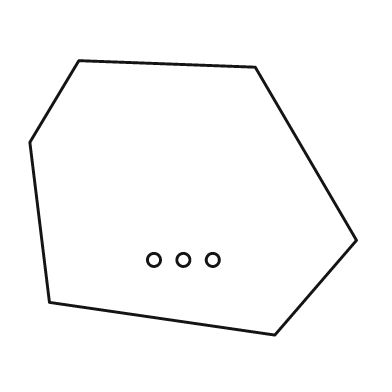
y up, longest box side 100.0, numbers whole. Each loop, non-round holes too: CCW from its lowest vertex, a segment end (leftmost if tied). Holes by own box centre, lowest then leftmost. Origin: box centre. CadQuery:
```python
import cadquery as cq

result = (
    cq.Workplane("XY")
    .moveTo(25.0, -42.0)
    .lineTo(50.0, -13.0)
    .lineTo(19.0, 40.0)
    .lineTo(-35.0, 42.0)
    .lineTo(-50.0, 17.0)
    .lineTo(-44.0, -32.0)
    .close()
    .moveTo(-12.0, -19.0)
    .circle(2.0)
    .moveTo(-3.0, -19.0)
    .circle(2.0)
    .moveTo(6.0, -19.0)
    .circle(2.0)
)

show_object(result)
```